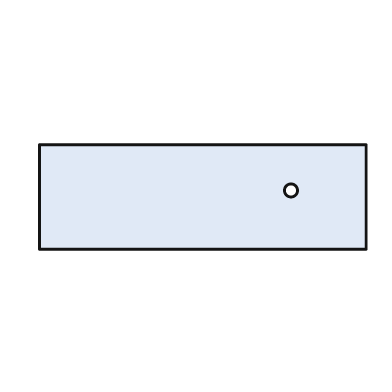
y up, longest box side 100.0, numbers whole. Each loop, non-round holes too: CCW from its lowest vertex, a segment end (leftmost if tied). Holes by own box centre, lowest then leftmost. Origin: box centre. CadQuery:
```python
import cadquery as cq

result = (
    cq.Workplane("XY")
    .moveTo(-50.0, -16.0)
    .lineTo(50.0, -16.0)
    .lineTo(50.0, 16.0)
    .lineTo(-50.0, 16.0)
    .close()
    .moveTo(27.0, 2.0)
    .circle(2.0)
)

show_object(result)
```